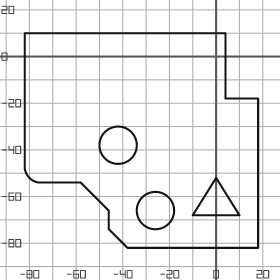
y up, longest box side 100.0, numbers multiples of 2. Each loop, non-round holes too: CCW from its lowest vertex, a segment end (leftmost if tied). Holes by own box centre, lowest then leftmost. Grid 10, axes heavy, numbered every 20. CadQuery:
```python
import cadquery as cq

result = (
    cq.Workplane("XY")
    .moveTo(-38.0, -82.0)
    .lineTo(18.0, -82.0)
    .lineTo(18.0, -18.0)
    .lineTo(4.0, -18.0)
    .lineTo(4.0, 10.0)
    .lineTo(-82.0, 10.0)
    .lineTo(-82.0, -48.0)
    .threePointArc((-80.0, -52.0), (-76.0, -54.0))
    .lineTo(-58.0, -54.0)
    .lineTo(-46.0, -66.0)
    .lineTo(-46.0, -74.0)
    .close()
    .moveTo(-26.0, -66.0)
    .circle(8.0)
    .moveTo(-10.0, -68.0)
    .lineTo(10.0, -68.0)
    .lineTo(0.0, -52.0)
    .close()
    .moveTo(-42.0, -38.0)
    .circle(8.0)
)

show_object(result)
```